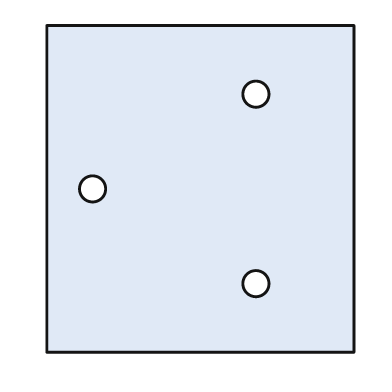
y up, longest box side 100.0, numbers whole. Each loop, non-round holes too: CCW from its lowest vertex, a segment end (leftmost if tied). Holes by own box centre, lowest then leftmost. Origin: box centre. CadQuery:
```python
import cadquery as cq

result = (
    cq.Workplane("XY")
    .moveTo(-47.0, -50.0)
    .lineTo(47.0, -50.0)
    .lineTo(47.0, 50.0)
    .lineTo(-47.0, 50.0)
    .close()
    .moveTo(17.0, -29.0)
    .circle(4.0)
    .moveTo(-33.0, 0.0)
    .circle(4.0)
    .moveTo(17.0, 29.0)
    .circle(4.0)
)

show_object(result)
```